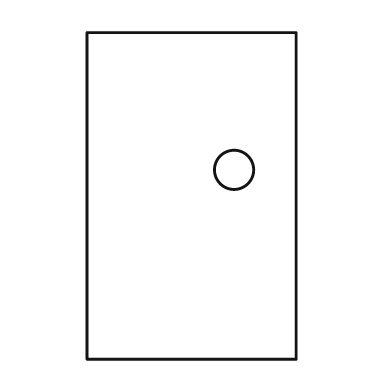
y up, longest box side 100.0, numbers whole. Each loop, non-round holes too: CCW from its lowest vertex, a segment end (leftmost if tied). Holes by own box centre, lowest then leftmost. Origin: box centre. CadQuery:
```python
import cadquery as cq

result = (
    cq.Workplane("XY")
    .moveTo(-32.0, -50.0)
    .lineTo(32.0, -50.0)
    .lineTo(32.0, 50.0)
    .lineTo(-32.0, 50.0)
    .close()
    .moveTo(13.0, 8.0)
    .circle(6.0)
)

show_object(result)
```